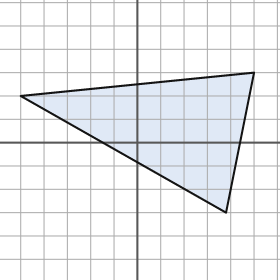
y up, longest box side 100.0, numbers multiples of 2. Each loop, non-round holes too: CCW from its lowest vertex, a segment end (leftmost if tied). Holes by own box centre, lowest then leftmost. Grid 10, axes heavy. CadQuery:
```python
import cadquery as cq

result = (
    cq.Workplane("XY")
    .moveTo(38.0, -30.0)
    .lineTo(50.0, 30.0)
    .lineTo(-50.0, 20.0)
    .close()
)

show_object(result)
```